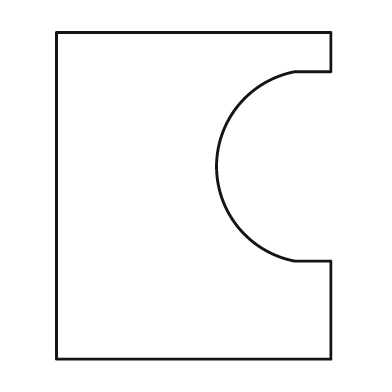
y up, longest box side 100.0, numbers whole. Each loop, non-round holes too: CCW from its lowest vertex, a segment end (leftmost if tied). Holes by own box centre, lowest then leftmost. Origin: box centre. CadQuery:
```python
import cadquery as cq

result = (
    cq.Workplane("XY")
    .moveTo(-42.0, -50.0)
    .lineTo(42.0, -50.0)
    .lineTo(42.0, -20.0)
    .lineTo(31.0, -20.0)
    .threePointArc((7.0, 9.0), (31.0, 38.0))
    .lineTo(42.0, 38.0)
    .lineTo(42.0, 50.0)
    .lineTo(-42.0, 50.0)
    .close()
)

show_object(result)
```